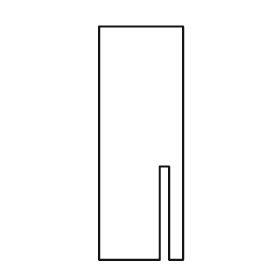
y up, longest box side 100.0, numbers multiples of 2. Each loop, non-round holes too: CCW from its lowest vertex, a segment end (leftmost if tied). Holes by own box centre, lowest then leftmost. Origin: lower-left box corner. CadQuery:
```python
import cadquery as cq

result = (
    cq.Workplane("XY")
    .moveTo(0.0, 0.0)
    .lineTo(26.0, 0.0)
    .lineTo(26.0, 40.0)
    .lineTo(30.0, 40.0)
    .lineTo(30.0, 0.0)
    .lineTo(36.0, 0.0)
    .lineTo(36.0, 100.0)
    .lineTo(0.0, 100.0)
    .close()
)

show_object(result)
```